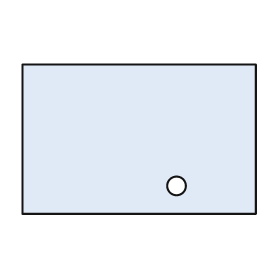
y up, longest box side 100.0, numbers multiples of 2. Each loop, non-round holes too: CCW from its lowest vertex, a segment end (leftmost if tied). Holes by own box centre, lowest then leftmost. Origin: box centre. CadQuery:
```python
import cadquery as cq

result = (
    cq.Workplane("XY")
    .moveTo(-50.0, -32.0)
    .lineTo(50.0, -32.0)
    .lineTo(50.0, 32.0)
    .lineTo(-50.0, 32.0)
    .close()
    .moveTo(16.0, -20.0)
    .circle(4.0)
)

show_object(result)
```